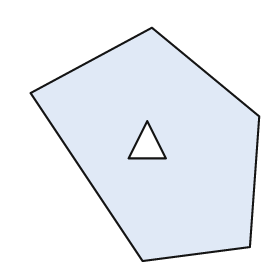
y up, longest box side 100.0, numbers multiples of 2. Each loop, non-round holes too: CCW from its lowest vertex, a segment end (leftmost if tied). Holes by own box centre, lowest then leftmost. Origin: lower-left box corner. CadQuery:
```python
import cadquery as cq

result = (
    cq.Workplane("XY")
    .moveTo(48.0, 0.0)
    .lineTo(94.0, 6.0)
    .lineTo(98.0, 62.0)
    .lineTo(52.0, 100.0)
    .lineTo(0.0, 72.0)
    .close()
    .moveTo(42.0, 44.0)
    .lineTo(58.0, 44.0)
    .lineTo(50.0, 60.0)
    .close()
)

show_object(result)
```